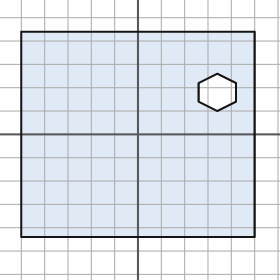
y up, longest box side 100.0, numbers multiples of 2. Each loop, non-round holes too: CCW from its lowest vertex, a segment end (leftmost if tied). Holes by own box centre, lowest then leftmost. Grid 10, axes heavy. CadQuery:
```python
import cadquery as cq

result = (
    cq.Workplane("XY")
    .moveTo(-50.0, -44.0)
    .lineTo(50.0, -44.0)
    .lineTo(50.0, 44.0)
    .lineTo(-50.0, 44.0)
    .close()
    .moveTo(34.0, 10.0)
    .lineTo(42.0, 14.0)
    .lineTo(42.0, 22.0)
    .lineTo(34.0, 26.0)
    .lineTo(26.0, 22.0)
    .lineTo(26.0, 14.0)
    .close()
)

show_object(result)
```